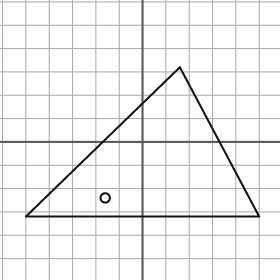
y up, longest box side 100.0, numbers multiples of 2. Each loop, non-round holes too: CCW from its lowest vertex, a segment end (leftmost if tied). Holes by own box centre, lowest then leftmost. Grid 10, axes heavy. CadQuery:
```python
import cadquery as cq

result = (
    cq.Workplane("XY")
    .moveTo(-50.0, -32.0)
    .lineTo(50.0, -32.0)
    .lineTo(16.0, 32.0)
    .close()
    .moveTo(-16.0, -24.0)
    .circle(2.0)
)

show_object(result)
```